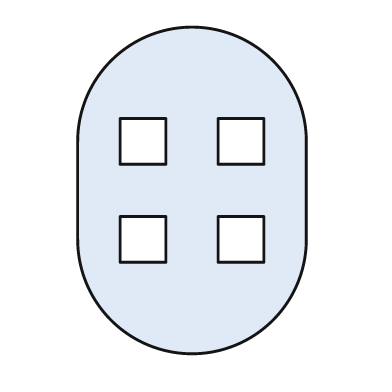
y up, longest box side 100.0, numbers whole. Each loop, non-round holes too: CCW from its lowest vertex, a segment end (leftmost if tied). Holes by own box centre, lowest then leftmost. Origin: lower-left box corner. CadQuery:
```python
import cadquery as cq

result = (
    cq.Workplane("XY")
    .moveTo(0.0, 35.0)
    .threePointArc((35.0, 0.0), (70.0, 35.0))
    .lineTo(70.0, 65.0)
    .threePointArc((35.0, 100.0), (0.0, 65.0))
    .close()
    .moveTo(13.0, 28.0)
    .lineTo(27.0, 28.0)
    .lineTo(27.0, 42.0)
    .lineTo(13.0, 42.0)
    .close()
    .moveTo(43.0, 28.0)
    .lineTo(57.0, 28.0)
    .lineTo(57.0, 42.0)
    .lineTo(43.0, 42.0)
    .close()
    .moveTo(13.0, 58.0)
    .lineTo(27.0, 58.0)
    .lineTo(27.0, 72.0)
    .lineTo(13.0, 72.0)
    .close()
    .moveTo(43.0, 58.0)
    .lineTo(57.0, 58.0)
    .lineTo(57.0, 72.0)
    .lineTo(43.0, 72.0)
    .close()
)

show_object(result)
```